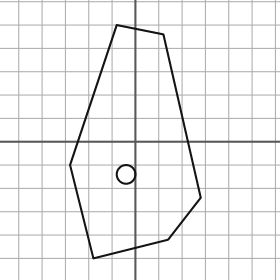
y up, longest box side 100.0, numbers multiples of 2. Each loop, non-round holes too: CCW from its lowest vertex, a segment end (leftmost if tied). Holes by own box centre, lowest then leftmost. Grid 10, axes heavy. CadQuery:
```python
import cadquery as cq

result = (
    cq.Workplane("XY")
    .moveTo(-18.0, -50.0)
    .lineTo(14.0, -42.0)
    .lineTo(28.0, -24.0)
    .lineTo(12.0, 46.0)
    .lineTo(-8.0, 50.0)
    .lineTo(-28.0, -10.0)
    .close()
    .moveTo(-4.0, -14.0)
    .circle(4.0)
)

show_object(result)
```